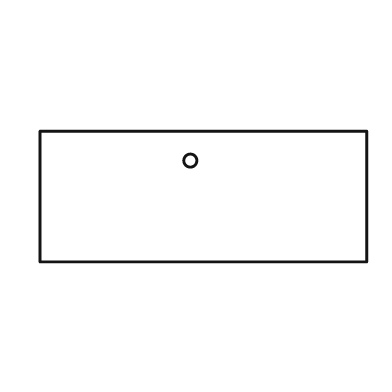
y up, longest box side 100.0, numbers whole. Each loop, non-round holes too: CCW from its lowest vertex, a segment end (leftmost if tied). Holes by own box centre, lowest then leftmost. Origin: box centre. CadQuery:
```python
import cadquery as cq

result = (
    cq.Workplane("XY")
    .moveTo(-50.0, -20.0)
    .lineTo(50.0, -20.0)
    .lineTo(50.0, 20.0)
    .lineTo(-50.0, 20.0)
    .close()
    .moveTo(-4.0, 11.0)
    .circle(2.0)
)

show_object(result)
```